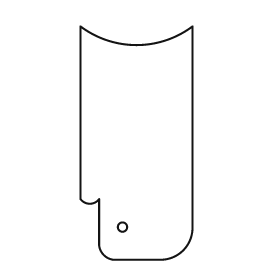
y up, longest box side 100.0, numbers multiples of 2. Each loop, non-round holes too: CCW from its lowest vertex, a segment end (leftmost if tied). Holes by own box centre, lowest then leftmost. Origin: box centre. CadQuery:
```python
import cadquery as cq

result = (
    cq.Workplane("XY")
    .moveTo(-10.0, -50.0)
    .lineTo(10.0, -50.0)
    .threePointArc((20.0, -46.0), (24.0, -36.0))
    .lineTo(24.0, 50.0)
    .threePointArc((0.0, 42.0), (-24.0, 50.0))
    .lineTo(-24.0, -24.0)
    .threePointArc((-20.0, -26.0), (-16.0, -24.0))
    .lineTo(-16.0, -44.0)
    .threePointArc((-14.0, -48.0), (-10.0, -50.0))
    .close()
    .moveTo(-6.0, -36.0)
    .circle(2.0)
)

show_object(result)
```